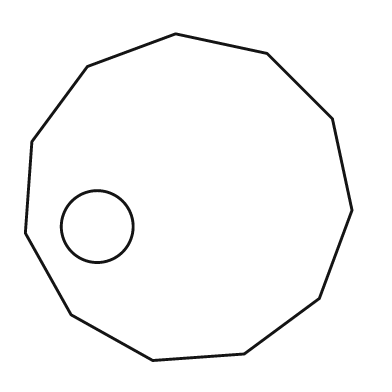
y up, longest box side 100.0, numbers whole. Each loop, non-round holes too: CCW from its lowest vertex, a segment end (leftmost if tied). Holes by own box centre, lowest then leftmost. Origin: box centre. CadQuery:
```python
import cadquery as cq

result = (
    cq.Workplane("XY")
    .moveTo(-11.0, -50.0)
    .lineTo(17.0, -48.0)
    .lineTo(40.0, -31.0)
    .lineTo(50.0, -4.0)
    .lineTo(44.0, 24.0)
    .lineTo(24.0, 44.0)
    .lineTo(-4.0, 50.0)
    .lineTo(-31.0, 40.0)
    .lineTo(-48.0, 17.0)
    .lineTo(-50.0, -11.0)
    .lineTo(-36.0, -36.0)
    .close()
    .moveTo(-28.0, -9.0)
    .circle(11.0)
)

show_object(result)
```